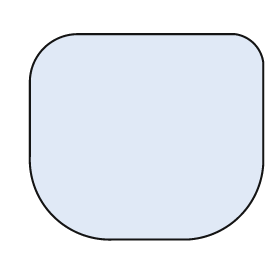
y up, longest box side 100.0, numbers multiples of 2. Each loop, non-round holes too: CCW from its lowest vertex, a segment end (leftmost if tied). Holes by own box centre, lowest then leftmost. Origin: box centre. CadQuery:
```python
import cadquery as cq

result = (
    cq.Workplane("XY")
    .moveTo(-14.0, -44.0)
    .lineTo(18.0, -44.0)
    .threePointArc((40.0, -34.0), (50.0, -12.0))
    .lineTo(50.0, 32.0)
    .threePointArc((46.0, 40.0), (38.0, 44.0))
    .lineTo(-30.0, 44.0)
    .threePointArc((-44.0, 38.0), (-50.0, 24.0))
    .lineTo(-50.0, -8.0)
    .threePointArc((-40.0, -34.0), (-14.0, -44.0))
    .close()
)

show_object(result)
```